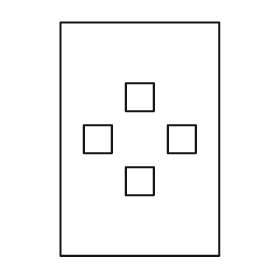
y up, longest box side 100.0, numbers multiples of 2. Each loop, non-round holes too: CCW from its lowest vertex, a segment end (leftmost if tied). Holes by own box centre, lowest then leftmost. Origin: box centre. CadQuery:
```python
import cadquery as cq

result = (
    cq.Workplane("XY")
    .moveTo(-34.0, -50.0)
    .lineTo(34.0, -50.0)
    .lineTo(34.0, 50.0)
    .lineTo(-34.0, 50.0)
    .close()
    .moveTo(-6.0, -24.0)
    .lineTo(6.0, -24.0)
    .lineTo(6.0, -12.0)
    .lineTo(-6.0, -12.0)
    .close()
    .moveTo(-24.0, -6.0)
    .lineTo(-12.0, -6.0)
    .lineTo(-12.0, 6.0)
    .lineTo(-24.0, 6.0)
    .close()
    .moveTo(12.0, -6.0)
    .lineTo(24.0, -6.0)
    .lineTo(24.0, 6.0)
    .lineTo(12.0, 6.0)
    .close()
    .moveTo(-6.0, 12.0)
    .lineTo(6.0, 12.0)
    .lineTo(6.0, 24.0)
    .lineTo(-6.0, 24.0)
    .close()
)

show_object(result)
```